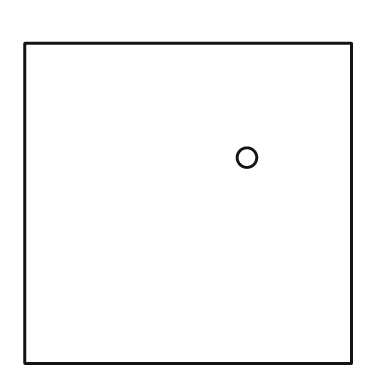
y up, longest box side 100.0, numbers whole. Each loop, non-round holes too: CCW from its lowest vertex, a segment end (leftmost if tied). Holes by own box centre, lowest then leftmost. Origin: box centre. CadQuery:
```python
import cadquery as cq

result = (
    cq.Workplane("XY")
    .moveTo(-50.0, -49.0)
    .lineTo(50.0, -49.0)
    .lineTo(50.0, 49.0)
    .lineTo(-50.0, 49.0)
    .close()
    .moveTo(18.0, 14.0)
    .circle(3.0)
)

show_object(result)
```